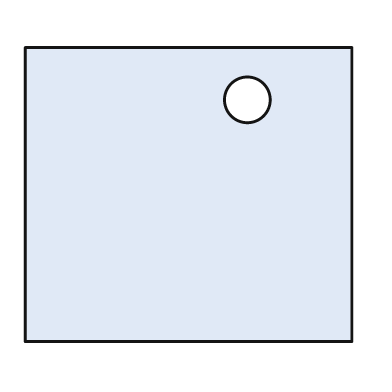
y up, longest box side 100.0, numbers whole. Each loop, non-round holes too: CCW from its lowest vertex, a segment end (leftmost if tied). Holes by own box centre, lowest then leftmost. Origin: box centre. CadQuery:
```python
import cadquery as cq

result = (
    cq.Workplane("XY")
    .moveTo(-50.0, -45.0)
    .lineTo(50.0, -45.0)
    .lineTo(50.0, 45.0)
    .lineTo(-50.0, 45.0)
    .close()
    .moveTo(18.0, 29.0)
    .circle(7.0)
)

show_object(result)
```